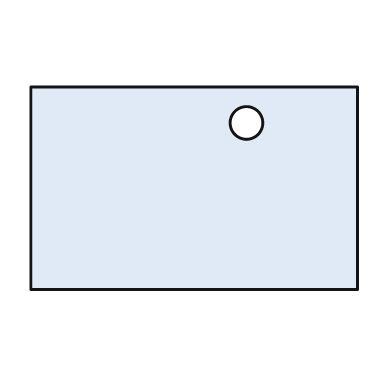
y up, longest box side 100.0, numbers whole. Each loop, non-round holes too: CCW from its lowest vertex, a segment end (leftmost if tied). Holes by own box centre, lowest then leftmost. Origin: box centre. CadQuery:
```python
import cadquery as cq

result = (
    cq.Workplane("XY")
    .moveTo(-50.0, -31.0)
    .lineTo(50.0, -31.0)
    .lineTo(50.0, 31.0)
    .lineTo(-50.0, 31.0)
    .close()
    .moveTo(16.0, 20.0)
    .circle(5.0)
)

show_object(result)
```